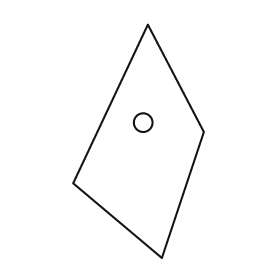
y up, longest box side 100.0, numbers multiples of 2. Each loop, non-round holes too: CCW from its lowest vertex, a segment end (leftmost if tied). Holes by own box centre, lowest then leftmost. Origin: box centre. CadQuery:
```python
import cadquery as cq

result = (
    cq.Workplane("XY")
    .moveTo(10.0, -50.0)
    .lineTo(28.0, 4.0)
    .lineTo(4.0, 50.0)
    .lineTo(-28.0, -18.0)
    .close()
    .moveTo(2.0, 8.0)
    .circle(4.0)
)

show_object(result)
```